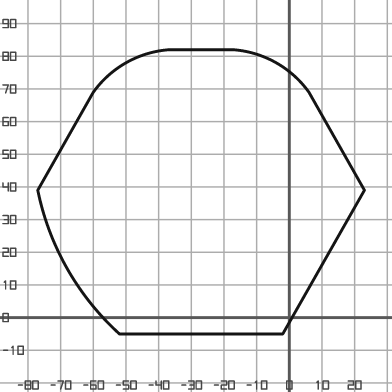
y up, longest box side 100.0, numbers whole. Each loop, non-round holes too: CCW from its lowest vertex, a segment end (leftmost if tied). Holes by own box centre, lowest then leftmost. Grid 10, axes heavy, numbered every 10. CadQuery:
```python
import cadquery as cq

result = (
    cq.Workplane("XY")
    .moveTo(-52.0, -5.0)
    .lineTo(-2.0, -5.0)
    .lineTo(23.0, 39.0)
    .lineTo(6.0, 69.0)
    .threePointArc((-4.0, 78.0), (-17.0, 82.0))
    .lineTo(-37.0, 82.0)
    .threePointArc((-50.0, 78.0), (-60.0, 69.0))
    .lineTo(-77.0, 39.0)
    .threePointArc((-68.0, 15.0), (-52.0, -5.0))
    .close()
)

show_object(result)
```